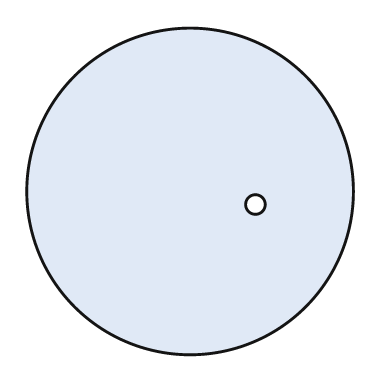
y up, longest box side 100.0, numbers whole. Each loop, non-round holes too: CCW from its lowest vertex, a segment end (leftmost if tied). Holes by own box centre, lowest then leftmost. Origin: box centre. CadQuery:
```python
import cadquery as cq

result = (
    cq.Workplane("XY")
    .moveTo(0.0, 0.0)
    .circle(50.0)
    .moveTo(20.0, -4.0)
    .circle(3.0)
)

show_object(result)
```